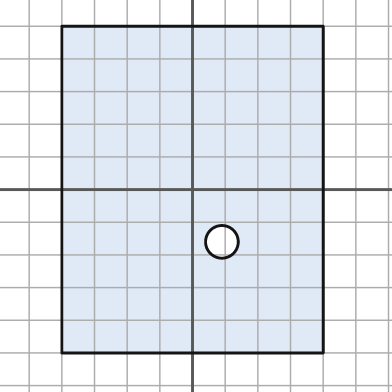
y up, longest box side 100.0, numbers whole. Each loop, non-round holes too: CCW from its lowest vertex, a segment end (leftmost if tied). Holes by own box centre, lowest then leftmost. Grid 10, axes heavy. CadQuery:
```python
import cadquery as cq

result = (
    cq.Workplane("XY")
    .moveTo(-40.0, -50.0)
    .lineTo(40.0, -50.0)
    .lineTo(40.0, 50.0)
    .lineTo(-40.0, 50.0)
    .close()
    .moveTo(9.0, -16.0)
    .circle(5.0)
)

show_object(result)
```